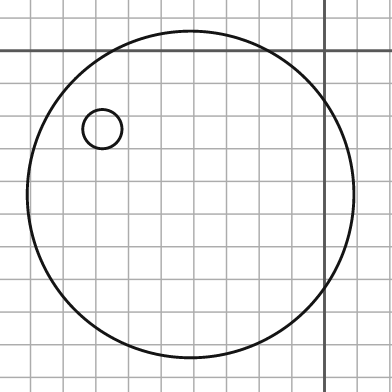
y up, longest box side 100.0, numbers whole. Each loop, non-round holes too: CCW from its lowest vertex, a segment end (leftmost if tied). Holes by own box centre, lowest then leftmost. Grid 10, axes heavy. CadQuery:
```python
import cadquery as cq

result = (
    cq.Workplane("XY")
    .moveTo(-41.0, -44.0)
    .circle(50.0)
    .moveTo(-68.0, -24.0)
    .circle(6.0)
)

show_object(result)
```